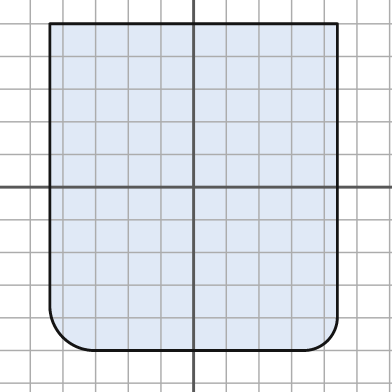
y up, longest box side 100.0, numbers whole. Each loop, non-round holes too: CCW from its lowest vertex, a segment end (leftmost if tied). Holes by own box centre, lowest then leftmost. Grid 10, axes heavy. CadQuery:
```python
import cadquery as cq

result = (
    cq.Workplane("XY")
    .moveTo(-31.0, -50.0)
    .lineTo(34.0, -50.0)
    .threePointArc((41.0, -47.0), (44.0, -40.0))
    .lineTo(44.0, 50.0)
    .lineTo(-44.0, 50.0)
    .lineTo(-44.0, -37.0)
    .threePointArc((-40.0, -46.0), (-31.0, -50.0))
    .close()
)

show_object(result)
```